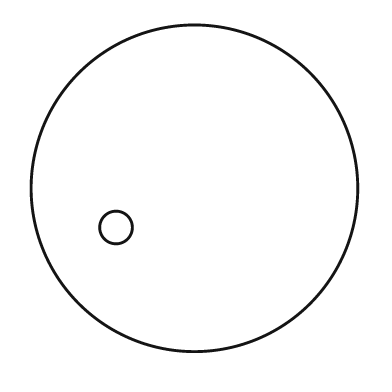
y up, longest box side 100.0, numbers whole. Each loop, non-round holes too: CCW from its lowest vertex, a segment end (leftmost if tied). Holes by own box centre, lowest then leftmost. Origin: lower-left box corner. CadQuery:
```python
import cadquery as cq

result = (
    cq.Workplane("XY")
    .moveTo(50.0, 50.0)
    .circle(50.0)
    .moveTo(26.0, 38.0)
    .circle(5.0)
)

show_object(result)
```